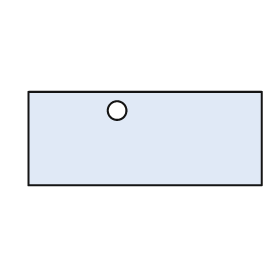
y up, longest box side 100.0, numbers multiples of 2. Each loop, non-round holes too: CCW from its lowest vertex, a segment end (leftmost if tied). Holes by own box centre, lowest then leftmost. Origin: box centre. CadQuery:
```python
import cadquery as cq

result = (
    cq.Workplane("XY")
    .moveTo(-50.0, -20.0)
    .lineTo(50.0, -20.0)
    .lineTo(50.0, 20.0)
    .lineTo(-50.0, 20.0)
    .close()
    .moveTo(-12.0, 12.0)
    .circle(4.0)
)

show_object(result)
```